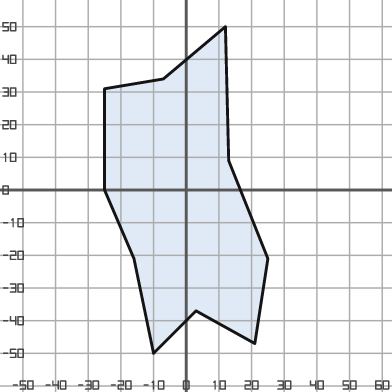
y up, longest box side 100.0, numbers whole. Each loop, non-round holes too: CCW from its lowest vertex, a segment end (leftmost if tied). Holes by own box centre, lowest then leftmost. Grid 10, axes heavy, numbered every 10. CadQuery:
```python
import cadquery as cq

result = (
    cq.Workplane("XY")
    .moveTo(-10.0, -50.0)
    .lineTo(3.0, -37.0)
    .lineTo(21.0, -47.0)
    .lineTo(25.0, -21.0)
    .lineTo(13.0, 9.0)
    .lineTo(12.0, 50.0)
    .lineTo(-7.0, 34.0)
    .lineTo(-25.0, 31.0)
    .lineTo(-25.0, 0.0)
    .lineTo(-16.0, -21.0)
    .close()
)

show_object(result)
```